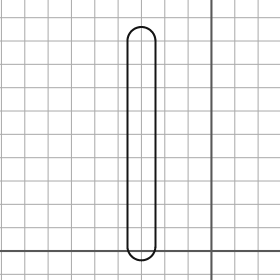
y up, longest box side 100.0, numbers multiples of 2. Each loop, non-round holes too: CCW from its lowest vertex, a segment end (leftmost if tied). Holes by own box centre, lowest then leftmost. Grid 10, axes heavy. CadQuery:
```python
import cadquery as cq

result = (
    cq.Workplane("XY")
    .moveTo(-36.0, 2.0)
    .threePointArc((-30.0, -4.0), (-24.0, 2.0))
    .lineTo(-24.0, 90.0)
    .threePointArc((-30.0, 96.0), (-36.0, 90.0))
    .close()
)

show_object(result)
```